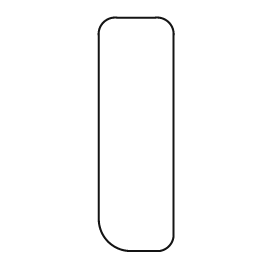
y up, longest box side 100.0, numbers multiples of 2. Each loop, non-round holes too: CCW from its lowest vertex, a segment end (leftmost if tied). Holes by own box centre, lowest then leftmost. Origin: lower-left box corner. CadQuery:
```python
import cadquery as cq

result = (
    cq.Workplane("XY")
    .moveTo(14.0, 0.0)
    .lineTo(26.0, 0.0)
    .threePointArc((30.0, 2.0), (32.0, 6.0))
    .lineTo(32.0, 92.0)
    .threePointArc((30.0, 98.0), (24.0, 100.0))
    .lineTo(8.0, 100.0)
    .threePointArc((2.0, 98.0), (0.0, 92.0))
    .lineTo(0.0, 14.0)
    .threePointArc((4.0, 4.0), (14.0, 0.0))
    .close()
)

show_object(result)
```